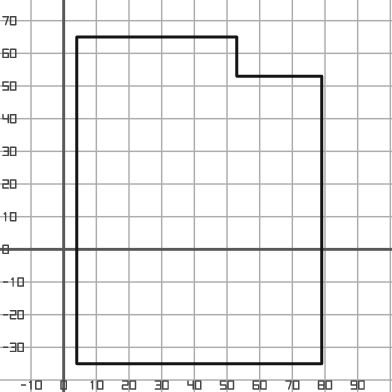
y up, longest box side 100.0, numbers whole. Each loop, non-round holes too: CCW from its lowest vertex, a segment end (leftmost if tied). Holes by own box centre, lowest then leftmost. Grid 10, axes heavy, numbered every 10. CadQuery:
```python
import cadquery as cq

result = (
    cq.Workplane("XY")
    .moveTo(4.0, -35.0)
    .lineTo(79.0, -35.0)
    .lineTo(79.0, 53.0)
    .lineTo(53.0, 53.0)
    .lineTo(53.0, 65.0)
    .lineTo(4.0, 65.0)
    .close()
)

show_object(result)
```